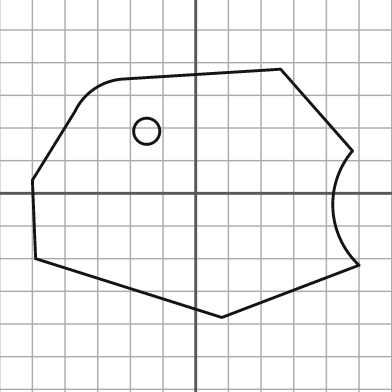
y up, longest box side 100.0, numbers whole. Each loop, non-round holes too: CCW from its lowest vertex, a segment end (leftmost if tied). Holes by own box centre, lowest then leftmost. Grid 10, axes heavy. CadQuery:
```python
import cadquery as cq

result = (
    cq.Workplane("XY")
    .moveTo(8.0, -38.0)
    .lineTo(50.0, -22.0)
    .threePointArc((42.0, -5.0), (48.0, 13.0))
    .lineTo(26.0, 38.0)
    .lineTo(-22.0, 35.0)
    .threePointArc((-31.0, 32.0), (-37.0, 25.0))
    .lineTo(-50.0, 4.0)
    .lineTo(-49.0, -20.0)
    .close()
    .moveTo(-15.0, 19.0)
    .circle(4.0)
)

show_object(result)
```